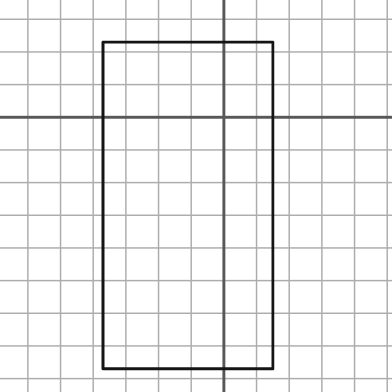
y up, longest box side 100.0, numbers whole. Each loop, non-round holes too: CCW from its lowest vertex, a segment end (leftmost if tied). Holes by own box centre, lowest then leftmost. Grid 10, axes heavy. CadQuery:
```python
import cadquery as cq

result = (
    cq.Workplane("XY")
    .moveTo(-37.0, -77.0)
    .lineTo(15.0, -77.0)
    .lineTo(15.0, 23.0)
    .lineTo(-37.0, 23.0)
    .close()
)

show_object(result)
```